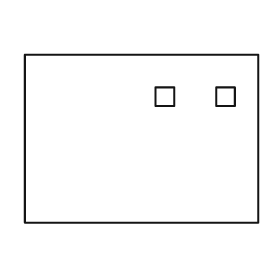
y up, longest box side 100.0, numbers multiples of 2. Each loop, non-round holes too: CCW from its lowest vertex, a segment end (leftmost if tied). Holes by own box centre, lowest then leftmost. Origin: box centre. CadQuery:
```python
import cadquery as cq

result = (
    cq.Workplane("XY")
    .moveTo(-50.0, -36.0)
    .lineTo(50.0, -36.0)
    .lineTo(50.0, 36.0)
    .lineTo(-50.0, 36.0)
    .close()
    .moveTo(6.0, 14.0)
    .lineTo(14.0, 14.0)
    .lineTo(14.0, 22.0)
    .lineTo(6.0, 22.0)
    .close()
    .moveTo(32.0, 14.0)
    .lineTo(40.0, 14.0)
    .lineTo(40.0, 22.0)
    .lineTo(32.0, 22.0)
    .close()
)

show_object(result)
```